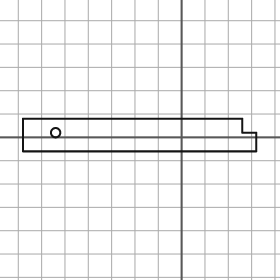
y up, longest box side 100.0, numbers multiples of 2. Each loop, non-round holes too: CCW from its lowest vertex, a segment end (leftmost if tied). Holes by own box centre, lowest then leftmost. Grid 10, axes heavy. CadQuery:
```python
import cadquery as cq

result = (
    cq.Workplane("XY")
    .moveTo(-68.0, -6.0)
    .lineTo(32.0, -6.0)
    .lineTo(32.0, 2.0)
    .lineTo(26.0, 2.0)
    .lineTo(26.0, 8.0)
    .lineTo(-68.0, 8.0)
    .close()
    .moveTo(-54.0, 2.0)
    .circle(2.0)
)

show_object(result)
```